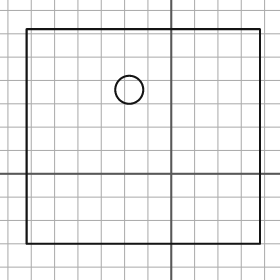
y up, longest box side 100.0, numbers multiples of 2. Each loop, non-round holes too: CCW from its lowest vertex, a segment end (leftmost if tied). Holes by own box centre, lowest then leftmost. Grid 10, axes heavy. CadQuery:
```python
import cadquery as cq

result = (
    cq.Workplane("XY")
    .moveTo(-62.0, -30.0)
    .lineTo(38.0, -30.0)
    .lineTo(38.0, 62.0)
    .lineTo(-62.0, 62.0)
    .close()
    .moveTo(-18.0, 36.0)
    .circle(6.0)
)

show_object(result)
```